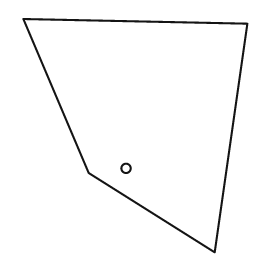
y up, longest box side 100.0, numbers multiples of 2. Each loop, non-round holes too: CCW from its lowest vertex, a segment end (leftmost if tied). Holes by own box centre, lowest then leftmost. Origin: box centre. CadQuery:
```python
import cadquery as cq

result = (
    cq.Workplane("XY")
    .moveTo(34.0, -50.0)
    .lineTo(48.0, 48.0)
    .lineTo(-48.0, 50.0)
    .lineTo(-20.0, -16.0)
    .close()
    .moveTo(-4.0, -14.0)
    .circle(2.0)
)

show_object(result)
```